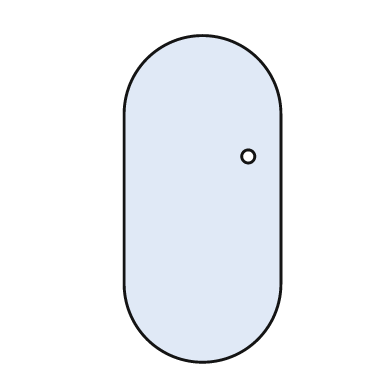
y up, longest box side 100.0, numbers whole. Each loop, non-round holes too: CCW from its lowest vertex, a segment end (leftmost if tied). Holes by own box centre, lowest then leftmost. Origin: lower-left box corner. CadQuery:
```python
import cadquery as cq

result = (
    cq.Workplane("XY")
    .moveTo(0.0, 24.0)
    .threePointArc((24.0, 0.0), (48.0, 24.0))
    .lineTo(48.0, 76.0)
    .threePointArc((24.0, 100.0), (0.0, 76.0))
    .close()
    .moveTo(38.0, 63.0)
    .circle(2.0)
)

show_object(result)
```